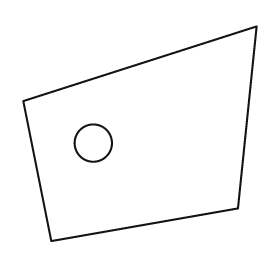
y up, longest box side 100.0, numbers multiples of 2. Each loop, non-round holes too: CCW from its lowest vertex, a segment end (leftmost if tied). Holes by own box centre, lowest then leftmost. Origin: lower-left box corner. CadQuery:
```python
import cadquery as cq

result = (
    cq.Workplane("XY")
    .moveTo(12.0, 0.0)
    .lineTo(92.0, 14.0)
    .lineTo(100.0, 92.0)
    .lineTo(0.0, 60.0)
    .close()
    .moveTo(30.0, 42.0)
    .circle(8.0)
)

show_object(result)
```